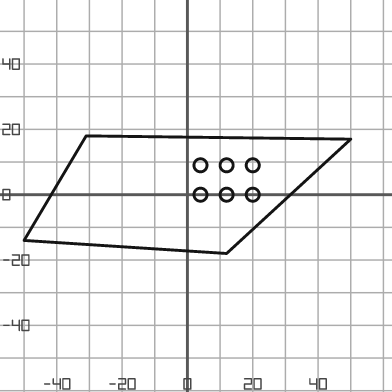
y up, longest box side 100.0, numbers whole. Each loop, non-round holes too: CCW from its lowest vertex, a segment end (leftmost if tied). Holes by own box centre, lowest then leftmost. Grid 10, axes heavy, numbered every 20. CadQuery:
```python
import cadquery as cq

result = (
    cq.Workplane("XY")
    .moveTo(12.0, -18.0)
    .lineTo(50.0, 17.0)
    .lineTo(-31.0, 18.0)
    .lineTo(-50.0, -14.0)
    .close()
    .moveTo(4.0, 0.0)
    .circle(2.0)
    .moveTo(12.0, 0.0)
    .circle(2.0)
    .moveTo(20.0, 0.0)
    .circle(2.0)
    .moveTo(4.0, 9.0)
    .circle(2.0)
    .moveTo(12.0, 9.0)
    .circle(2.0)
    .moveTo(20.0, 9.0)
    .circle(2.0)
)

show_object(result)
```